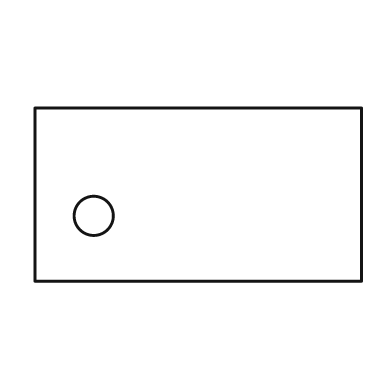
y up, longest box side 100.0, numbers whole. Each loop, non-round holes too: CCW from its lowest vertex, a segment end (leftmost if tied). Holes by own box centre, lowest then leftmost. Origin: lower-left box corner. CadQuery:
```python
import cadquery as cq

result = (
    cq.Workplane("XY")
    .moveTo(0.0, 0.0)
    .lineTo(100.0, 0.0)
    .lineTo(100.0, 53.0)
    .lineTo(0.0, 53.0)
    .close()
    .moveTo(18.0, 20.0)
    .circle(6.0)
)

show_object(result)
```